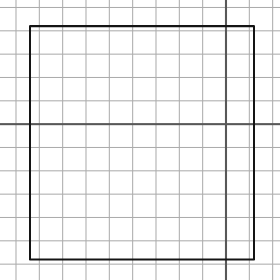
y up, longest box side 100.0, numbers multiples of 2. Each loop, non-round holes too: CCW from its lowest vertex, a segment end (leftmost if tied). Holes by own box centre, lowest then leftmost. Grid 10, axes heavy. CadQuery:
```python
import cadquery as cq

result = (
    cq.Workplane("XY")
    .moveTo(-84.0, -58.0)
    .lineTo(12.0, -58.0)
    .lineTo(12.0, 42.0)
    .lineTo(-84.0, 42.0)
    .close()
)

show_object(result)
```